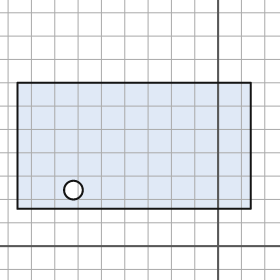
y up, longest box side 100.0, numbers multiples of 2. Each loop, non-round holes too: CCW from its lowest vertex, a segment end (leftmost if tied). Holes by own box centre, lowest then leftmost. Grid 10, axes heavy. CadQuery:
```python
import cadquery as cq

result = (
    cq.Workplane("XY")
    .moveTo(-86.0, 16.0)
    .lineTo(14.0, 16.0)
    .lineTo(14.0, 70.0)
    .lineTo(-86.0, 70.0)
    .close()
    .moveTo(-62.0, 24.0)
    .circle(4.0)
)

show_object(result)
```